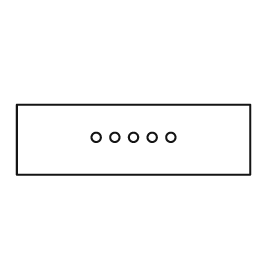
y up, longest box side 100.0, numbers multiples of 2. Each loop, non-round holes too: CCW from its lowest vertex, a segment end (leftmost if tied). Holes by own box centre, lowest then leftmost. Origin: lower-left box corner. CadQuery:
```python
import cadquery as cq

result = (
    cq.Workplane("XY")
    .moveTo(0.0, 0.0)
    .lineTo(100.0, 0.0)
    .lineTo(100.0, 30.0)
    .lineTo(0.0, 30.0)
    .close()
    .moveTo(34.0, 16.0)
    .circle(2.0)
    .moveTo(42.0, 16.0)
    .circle(2.0)
    .moveTo(50.0, 16.0)
    .circle(2.0)
    .moveTo(58.0, 16.0)
    .circle(2.0)
    .moveTo(66.0, 16.0)
    .circle(2.0)
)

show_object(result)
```